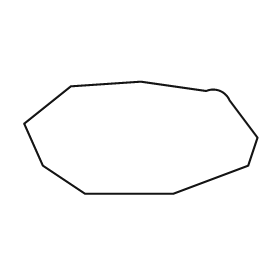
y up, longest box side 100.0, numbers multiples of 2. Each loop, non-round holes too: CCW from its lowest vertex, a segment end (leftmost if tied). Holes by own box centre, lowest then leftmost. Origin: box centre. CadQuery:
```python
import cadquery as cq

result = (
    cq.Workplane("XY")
    .moveTo(-24.0, -24.0)
    .lineTo(14.0, -24.0)
    .lineTo(46.0, -12.0)
    .lineTo(50.0, 0.0)
    .lineTo(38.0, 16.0)
    .threePointArc((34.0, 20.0), (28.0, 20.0))
    .lineTo(0.0, 24.0)
    .lineTo(-30.0, 22.0)
    .lineTo(-50.0, 6.0)
    .lineTo(-42.0, -12.0)
    .close()
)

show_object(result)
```